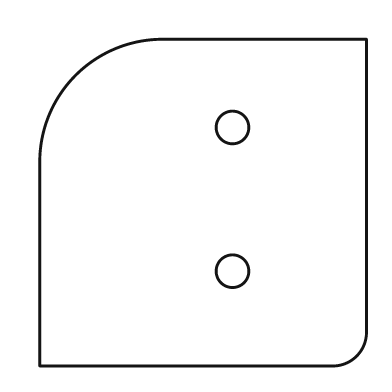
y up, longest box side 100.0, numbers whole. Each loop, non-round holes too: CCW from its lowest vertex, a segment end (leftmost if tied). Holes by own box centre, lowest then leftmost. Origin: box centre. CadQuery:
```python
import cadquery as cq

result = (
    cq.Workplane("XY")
    .moveTo(-50.0, -50.0)
    .lineTo(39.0, -50.0)
    .threePointArc((47.0, -47.0), (50.0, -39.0))
    .lineTo(50.0, 50.0)
    .lineTo(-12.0, 50.0)
    .threePointArc((-39.0, 39.0), (-50.0, 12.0))
    .close()
    .moveTo(9.0, -21.0)
    .circle(5.0)
    .moveTo(9.0, 23.0)
    .circle(5.0)
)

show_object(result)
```